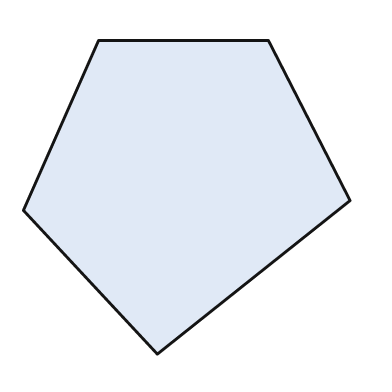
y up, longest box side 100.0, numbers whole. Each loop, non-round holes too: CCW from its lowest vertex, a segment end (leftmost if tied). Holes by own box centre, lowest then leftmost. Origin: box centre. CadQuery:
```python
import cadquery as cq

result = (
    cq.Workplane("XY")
    .moveTo(-9.0, -48.0)
    .lineTo(50.0, -1.0)
    .lineTo(25.0, 48.0)
    .lineTo(-27.0, 48.0)
    .lineTo(-50.0, -4.0)
    .close()
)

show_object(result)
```